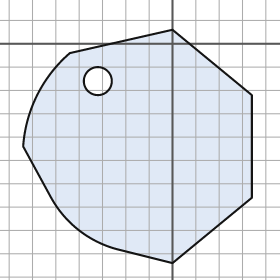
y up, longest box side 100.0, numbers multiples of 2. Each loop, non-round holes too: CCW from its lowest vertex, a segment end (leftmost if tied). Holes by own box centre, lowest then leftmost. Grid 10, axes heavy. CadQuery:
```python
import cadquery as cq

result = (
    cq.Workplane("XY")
    .moveTo(0.0, -94.0)
    .lineTo(34.0, -66.0)
    .lineTo(34.0, -22.0)
    .lineTo(0.0, 6.0)
    .lineTo(-44.0, -4.0)
    .threePointArc((-58.0, -22.0), (-64.0, -44.0))
    .lineTo(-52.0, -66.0)
    .threePointArc((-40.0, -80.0), (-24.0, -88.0))
    .close()
    .moveTo(-32.0, -16.0)
    .circle(6.0)
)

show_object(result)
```